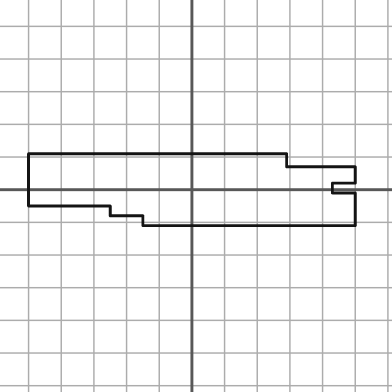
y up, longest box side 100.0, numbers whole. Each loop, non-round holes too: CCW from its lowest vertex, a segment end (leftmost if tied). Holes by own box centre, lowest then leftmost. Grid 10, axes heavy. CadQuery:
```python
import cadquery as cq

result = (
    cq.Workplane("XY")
    .moveTo(-15.0, -11.0)
    .lineTo(50.0, -11.0)
    .lineTo(50.0, -1.0)
    .lineTo(43.0, -1.0)
    .lineTo(43.0, 2.0)
    .lineTo(50.0, 2.0)
    .lineTo(50.0, 7.0)
    .lineTo(29.0, 7.0)
    .lineTo(29.0, 11.0)
    .lineTo(-50.0, 11.0)
    .lineTo(-50.0, -5.0)
    .lineTo(-25.0, -5.0)
    .lineTo(-25.0, -8.0)
    .lineTo(-15.0, -8.0)
    .close()
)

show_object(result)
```